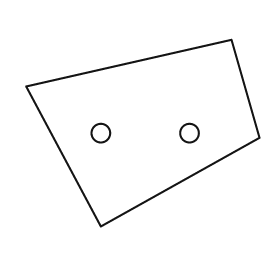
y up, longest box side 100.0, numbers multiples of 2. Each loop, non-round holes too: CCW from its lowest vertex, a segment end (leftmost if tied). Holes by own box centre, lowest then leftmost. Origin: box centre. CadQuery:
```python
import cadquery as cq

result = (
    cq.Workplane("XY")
    .moveTo(-18.0, -40.0)
    .lineTo(50.0, -2.0)
    .lineTo(38.0, 40.0)
    .lineTo(-50.0, 20.0)
    .close()
    .moveTo(-18.0, 0.0)
    .circle(4.0)
    .moveTo(20.0, 0.0)
    .circle(4.0)
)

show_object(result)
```